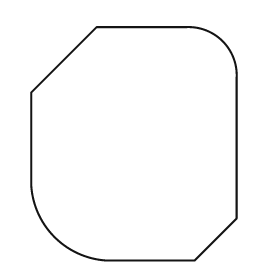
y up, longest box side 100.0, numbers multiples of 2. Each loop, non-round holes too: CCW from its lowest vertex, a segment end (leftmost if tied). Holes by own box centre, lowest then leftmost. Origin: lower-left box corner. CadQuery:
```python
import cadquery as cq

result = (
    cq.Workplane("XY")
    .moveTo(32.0, 0.0)
    .lineTo(70.0, 0.0)
    .lineTo(88.0, 18.0)
    .lineTo(88.0, 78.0)
    .threePointArc((82.0, 94.0), (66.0, 100.0))
    .lineTo(28.0, 100.0)
    .lineTo(0.0, 72.0)
    .lineTo(0.0, 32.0)
    .threePointArc((10.0, 10.0), (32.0, 0.0))
    .close()
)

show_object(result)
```